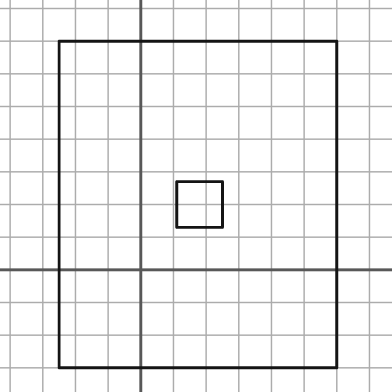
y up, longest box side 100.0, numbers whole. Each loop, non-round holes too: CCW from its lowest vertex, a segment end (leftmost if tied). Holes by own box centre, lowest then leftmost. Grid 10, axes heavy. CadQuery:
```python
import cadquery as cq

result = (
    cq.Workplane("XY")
    .moveTo(-25.0, -30.0)
    .lineTo(60.0, -30.0)
    .lineTo(60.0, 70.0)
    .lineTo(-25.0, 70.0)
    .close()
    .moveTo(11.0, 13.0)
    .lineTo(25.0, 13.0)
    .lineTo(25.0, 27.0)
    .lineTo(11.0, 27.0)
    .close()
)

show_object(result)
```